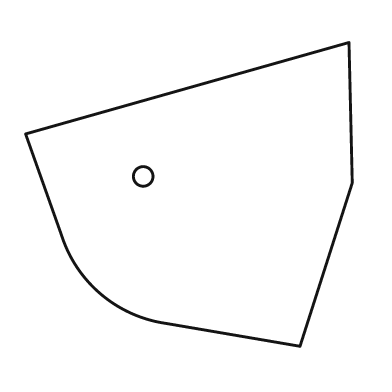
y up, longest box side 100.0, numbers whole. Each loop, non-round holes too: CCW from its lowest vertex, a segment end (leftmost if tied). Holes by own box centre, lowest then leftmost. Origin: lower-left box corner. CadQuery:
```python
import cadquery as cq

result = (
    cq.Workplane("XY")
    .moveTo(84.0, 0.0)
    .lineTo(100.0, 50.0)
    .lineTo(99.0, 93.0)
    .lineTo(0.0, 65.0)
    .lineTo(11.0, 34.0)
    .threePointArc((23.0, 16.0), (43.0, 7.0))
    .close()
    .moveTo(36.0, 52.0)
    .circle(3.0)
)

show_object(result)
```